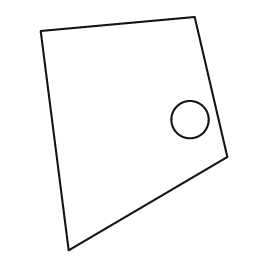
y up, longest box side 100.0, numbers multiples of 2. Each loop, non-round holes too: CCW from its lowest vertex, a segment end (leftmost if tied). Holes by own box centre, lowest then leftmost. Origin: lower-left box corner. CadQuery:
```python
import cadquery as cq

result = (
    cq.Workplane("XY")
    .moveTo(12.0, 0.0)
    .lineTo(80.0, 40.0)
    .lineTo(66.0, 100.0)
    .lineTo(0.0, 94.0)
    .close()
    .moveTo(64.0, 56.0)
    .circle(8.0)
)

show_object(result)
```